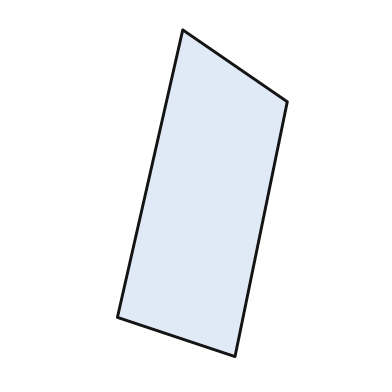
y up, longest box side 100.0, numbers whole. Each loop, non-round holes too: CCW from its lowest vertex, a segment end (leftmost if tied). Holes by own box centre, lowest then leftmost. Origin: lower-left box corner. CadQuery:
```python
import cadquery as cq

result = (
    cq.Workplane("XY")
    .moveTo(36.0, 0.0)
    .lineTo(52.0, 78.0)
    .lineTo(20.0, 100.0)
    .lineTo(0.0, 12.0)
    .close()
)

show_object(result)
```